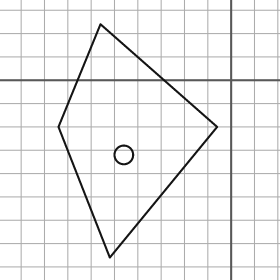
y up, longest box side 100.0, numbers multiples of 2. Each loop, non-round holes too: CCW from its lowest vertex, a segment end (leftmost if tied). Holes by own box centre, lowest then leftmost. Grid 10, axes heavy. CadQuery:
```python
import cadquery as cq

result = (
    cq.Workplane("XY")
    .moveTo(-52.0, -76.0)
    .lineTo(-6.0, -20.0)
    .lineTo(-56.0, 24.0)
    .lineTo(-74.0, -20.0)
    .close()
    .moveTo(-46.0, -32.0)
    .circle(4.0)
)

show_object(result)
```